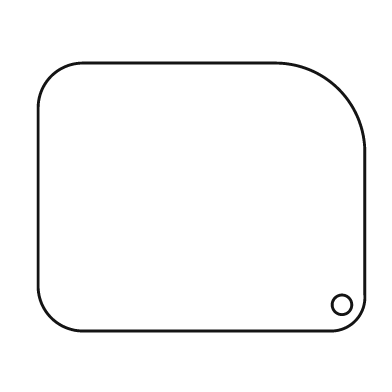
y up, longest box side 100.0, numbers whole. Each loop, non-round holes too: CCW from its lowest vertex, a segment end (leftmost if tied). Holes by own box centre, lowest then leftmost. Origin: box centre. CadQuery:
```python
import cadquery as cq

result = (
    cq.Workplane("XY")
    .moveTo(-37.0, -41.0)
    .lineTo(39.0, -41.0)
    .threePointArc((47.0, -38.0), (50.0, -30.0))
    .lineTo(50.0, 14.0)
    .threePointArc((42.0, 33.0), (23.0, 41.0))
    .lineTo(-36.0, 41.0)
    .threePointArc((-46.0, 37.0), (-50.0, 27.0))
    .lineTo(-50.0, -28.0)
    .threePointArc((-46.0, -37.0), (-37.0, -41.0))
    .close()
    .moveTo(43.0, -33.0)
    .circle(3.0)
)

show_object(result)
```